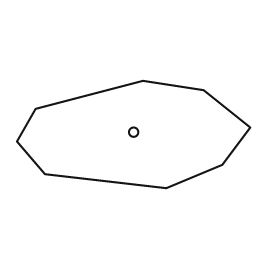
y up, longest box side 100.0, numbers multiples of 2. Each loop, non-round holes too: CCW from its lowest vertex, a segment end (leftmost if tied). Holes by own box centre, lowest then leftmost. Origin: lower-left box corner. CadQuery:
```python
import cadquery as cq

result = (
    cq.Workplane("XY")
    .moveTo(64.0, 0.0)
    .lineTo(88.0, 10.0)
    .lineTo(100.0, 26.0)
    .lineTo(80.0, 42.0)
    .lineTo(54.0, 46.0)
    .lineTo(8.0, 34.0)
    .lineTo(0.0, 20.0)
    .lineTo(12.0, 6.0)
    .close()
    .moveTo(50.0, 24.0)
    .circle(2.0)
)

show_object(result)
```